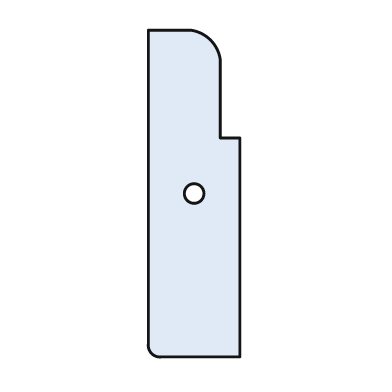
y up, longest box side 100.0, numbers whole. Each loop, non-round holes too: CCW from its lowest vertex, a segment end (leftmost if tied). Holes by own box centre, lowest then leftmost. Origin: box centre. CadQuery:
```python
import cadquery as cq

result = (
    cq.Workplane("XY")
    .moveTo(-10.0, -50.0)
    .lineTo(14.0, -50.0)
    .lineTo(14.0, 17.0)
    .lineTo(8.0, 17.0)
    .lineTo(8.0, 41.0)
    .threePointArc((5.0, 47.0), (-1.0, 50.0))
    .lineTo(-14.0, 50.0)
    .lineTo(-14.0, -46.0)
    .threePointArc((-13.0, -49.0), (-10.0, -50.0))
    .close()
    .moveTo(0.0, 0.0)
    .circle(3.0)
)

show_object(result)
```